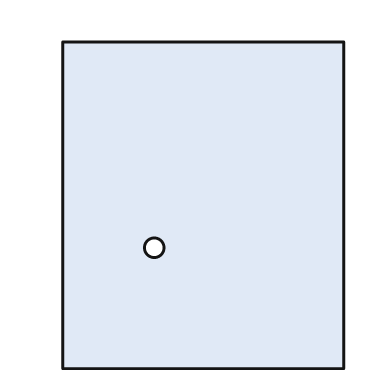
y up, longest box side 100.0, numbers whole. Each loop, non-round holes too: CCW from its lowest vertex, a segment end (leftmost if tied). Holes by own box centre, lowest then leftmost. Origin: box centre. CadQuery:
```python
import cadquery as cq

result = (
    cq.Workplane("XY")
    .moveTo(-43.0, -50.0)
    .lineTo(43.0, -50.0)
    .lineTo(43.0, 50.0)
    .lineTo(-43.0, 50.0)
    .close()
    .moveTo(-15.0, -13.0)
    .circle(3.0)
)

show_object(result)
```